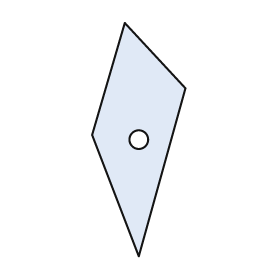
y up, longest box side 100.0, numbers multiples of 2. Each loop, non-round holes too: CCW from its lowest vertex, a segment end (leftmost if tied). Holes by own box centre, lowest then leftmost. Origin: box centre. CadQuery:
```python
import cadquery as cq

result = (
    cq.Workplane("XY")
    .moveTo(0.0, -50.0)
    .lineTo(20.0, 22.0)
    .lineTo(-6.0, 50.0)
    .lineTo(-20.0, 2.0)
    .close()
    .moveTo(0.0, 0.0)
    .circle(4.0)
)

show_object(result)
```